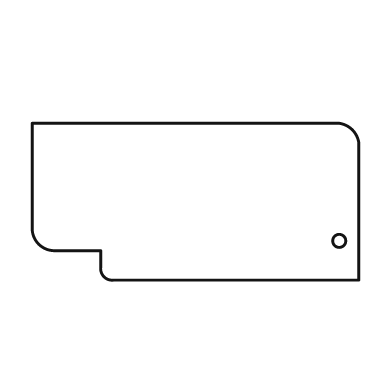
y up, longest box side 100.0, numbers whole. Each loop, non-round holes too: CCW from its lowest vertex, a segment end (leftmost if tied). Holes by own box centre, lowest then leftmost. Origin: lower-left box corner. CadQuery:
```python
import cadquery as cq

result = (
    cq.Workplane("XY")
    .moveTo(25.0, 0.0)
    .lineTo(100.0, 0.0)
    .lineTo(100.0, 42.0)
    .threePointArc((98.0, 46.0), (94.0, 48.0))
    .lineTo(0.0, 48.0)
    .lineTo(0.0, 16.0)
    .threePointArc((2.0, 11.0), (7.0, 9.0))
    .lineTo(21.0, 9.0)
    .lineTo(21.0, 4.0)
    .threePointArc((22.0, 1.0), (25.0, 0.0))
    .close()
    .moveTo(94.0, 12.0)
    .circle(2.0)
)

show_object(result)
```